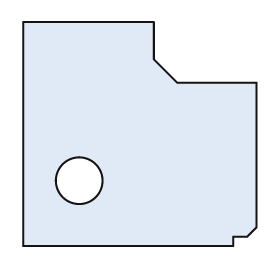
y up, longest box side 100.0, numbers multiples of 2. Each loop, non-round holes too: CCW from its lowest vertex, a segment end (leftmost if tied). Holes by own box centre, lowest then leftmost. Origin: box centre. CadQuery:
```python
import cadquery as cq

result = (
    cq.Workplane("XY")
    .moveTo(-50.0, -48.0)
    .lineTo(40.0, -48.0)
    .lineTo(40.0, -44.0)
    .lineTo(46.0, -44.0)
    .lineTo(50.0, -40.0)
    .lineTo(50.0, 22.0)
    .lineTo(16.0, 22.0)
    .lineTo(6.0, 32.0)
    .lineTo(6.0, 48.0)
    .lineTo(-50.0, 48.0)
    .close()
    .moveTo(-26.0, -20.0)
    .circle(10.0)
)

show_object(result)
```